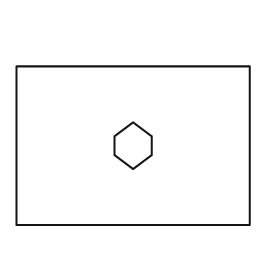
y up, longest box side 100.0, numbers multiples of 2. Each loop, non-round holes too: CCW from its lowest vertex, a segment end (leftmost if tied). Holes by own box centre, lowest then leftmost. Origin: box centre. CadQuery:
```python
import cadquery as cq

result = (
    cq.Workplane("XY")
    .moveTo(-50.0, -34.0)
    .lineTo(50.0, -34.0)
    .lineTo(50.0, 34.0)
    .lineTo(-50.0, 34.0)
    .close()
    .moveTo(0.0, -10.0)
    .lineTo(8.0, -4.0)
    .lineTo(8.0, 4.0)
    .lineTo(0.0, 10.0)
    .lineTo(-8.0, 4.0)
    .lineTo(-8.0, -4.0)
    .close()
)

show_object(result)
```